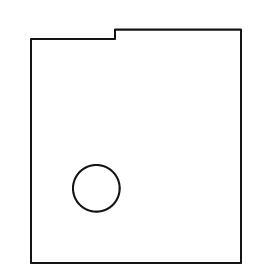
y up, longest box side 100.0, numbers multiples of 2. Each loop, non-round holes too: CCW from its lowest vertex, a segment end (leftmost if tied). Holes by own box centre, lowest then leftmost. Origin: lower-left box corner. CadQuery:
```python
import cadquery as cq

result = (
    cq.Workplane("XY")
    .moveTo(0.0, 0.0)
    .lineTo(90.0, 0.0)
    .lineTo(90.0, 100.0)
    .lineTo(36.0, 100.0)
    .lineTo(36.0, 96.0)
    .lineTo(0.0, 96.0)
    .close()
    .moveTo(28.0, 32.0)
    .circle(10.0)
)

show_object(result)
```